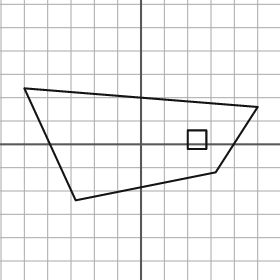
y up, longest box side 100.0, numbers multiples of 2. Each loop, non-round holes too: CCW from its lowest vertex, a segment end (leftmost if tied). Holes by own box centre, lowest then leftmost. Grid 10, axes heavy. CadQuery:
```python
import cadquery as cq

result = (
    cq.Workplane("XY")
    .moveTo(-28.0, -24.0)
    .lineTo(32.0, -12.0)
    .lineTo(50.0, 16.0)
    .lineTo(-50.0, 24.0)
    .close()
    .moveTo(20.0, -2.0)
    .lineTo(28.0, -2.0)
    .lineTo(28.0, 6.0)
    .lineTo(20.0, 6.0)
    .close()
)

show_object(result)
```